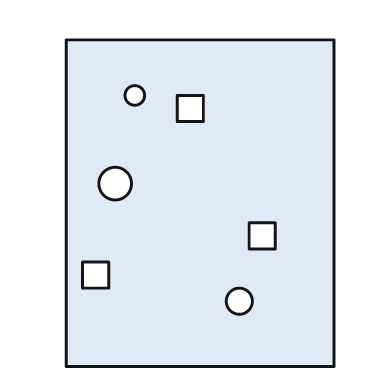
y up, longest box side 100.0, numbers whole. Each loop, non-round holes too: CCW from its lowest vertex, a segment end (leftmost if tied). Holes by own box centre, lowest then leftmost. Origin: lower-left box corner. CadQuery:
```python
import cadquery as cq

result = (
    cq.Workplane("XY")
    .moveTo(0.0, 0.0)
    .lineTo(82.0, 0.0)
    .lineTo(82.0, 100.0)
    .lineTo(0.0, 100.0)
    .close()
    .moveTo(53.0, 20.0)
    .circle(4.0)
    .moveTo(5.0, 24.0)
    .lineTo(13.0, 24.0)
    .lineTo(13.0, 32.0)
    .lineTo(5.0, 32.0)
    .close()
    .moveTo(56.0, 36.0)
    .lineTo(64.0, 36.0)
    .lineTo(64.0, 44.0)
    .lineTo(56.0, 44.0)
    .close()
    .moveTo(15.0, 56.0)
    .circle(5.0)
    .moveTo(34.0, 75.0)
    .lineTo(42.0, 75.0)
    .lineTo(42.0, 83.0)
    .lineTo(34.0, 83.0)
    .close()
    .moveTo(21.0, 83.0)
    .circle(3.0)
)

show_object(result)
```